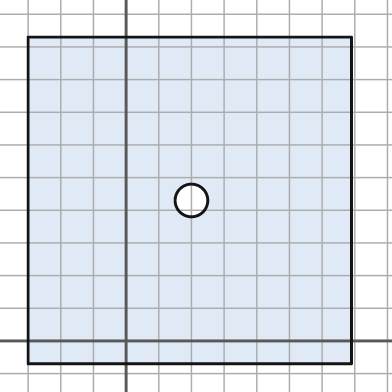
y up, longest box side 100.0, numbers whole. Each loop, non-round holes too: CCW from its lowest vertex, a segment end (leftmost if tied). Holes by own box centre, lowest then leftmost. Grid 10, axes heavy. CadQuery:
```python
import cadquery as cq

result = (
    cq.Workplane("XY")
    .moveTo(-30.0, -7.0)
    .lineTo(69.0, -7.0)
    .lineTo(69.0, 93.0)
    .lineTo(-30.0, 93.0)
    .close()
    .moveTo(20.0, 43.0)
    .circle(5.0)
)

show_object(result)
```